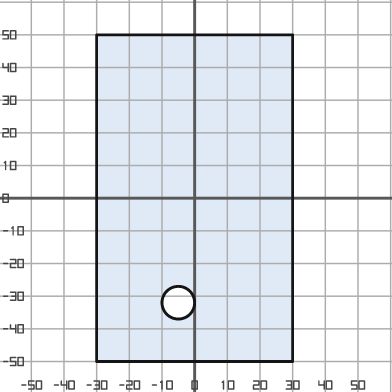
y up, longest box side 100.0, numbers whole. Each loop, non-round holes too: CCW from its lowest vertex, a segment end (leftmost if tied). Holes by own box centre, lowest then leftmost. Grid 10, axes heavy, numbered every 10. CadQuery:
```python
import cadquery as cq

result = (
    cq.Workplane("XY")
    .moveTo(-30.0, -50.0)
    .lineTo(30.0, -50.0)
    .lineTo(30.0, 50.0)
    .lineTo(-30.0, 50.0)
    .close()
    .moveTo(-5.0, -32.0)
    .circle(5.0)
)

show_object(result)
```